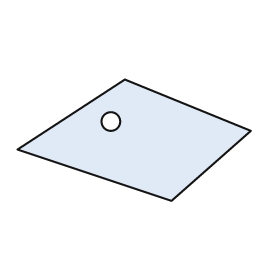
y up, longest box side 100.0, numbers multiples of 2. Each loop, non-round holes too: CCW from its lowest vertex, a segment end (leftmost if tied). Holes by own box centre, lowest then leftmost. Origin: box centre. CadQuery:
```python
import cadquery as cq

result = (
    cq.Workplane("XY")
    .moveTo(16.0, -26.0)
    .lineTo(50.0, 4.0)
    .lineTo(-4.0, 26.0)
    .lineTo(-50.0, -4.0)
    .close()
    .moveTo(-10.0, 8.0)
    .circle(4.0)
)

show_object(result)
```